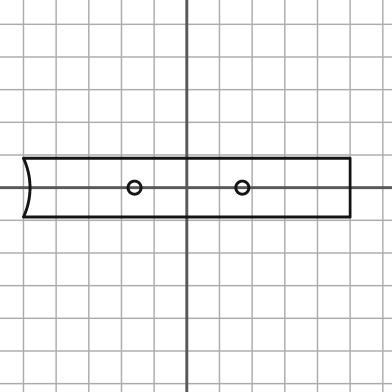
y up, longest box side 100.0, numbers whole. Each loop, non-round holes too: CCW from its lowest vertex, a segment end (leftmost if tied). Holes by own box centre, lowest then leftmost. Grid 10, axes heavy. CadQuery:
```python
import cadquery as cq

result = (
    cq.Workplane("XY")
    .moveTo(-50.0, -9.0)
    .lineTo(50.0, -9.0)
    .lineTo(50.0, 9.0)
    .lineTo(-50.0, 9.0)
    .threePointArc((-48.0, 0.0), (-50.0, -9.0))
    .close()
    .moveTo(-16.0, 0.0)
    .circle(2.0)
    .moveTo(17.0, 0.0)
    .circle(2.0)
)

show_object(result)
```